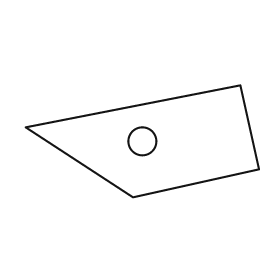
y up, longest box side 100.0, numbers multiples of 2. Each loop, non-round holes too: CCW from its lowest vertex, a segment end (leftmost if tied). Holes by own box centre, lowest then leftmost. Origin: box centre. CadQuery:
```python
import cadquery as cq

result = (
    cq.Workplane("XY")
    .moveTo(-4.0, -24.0)
    .lineTo(50.0, -12.0)
    .lineTo(42.0, 24.0)
    .lineTo(-50.0, 6.0)
    .close()
    .moveTo(0.0, 0.0)
    .circle(6.0)
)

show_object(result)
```